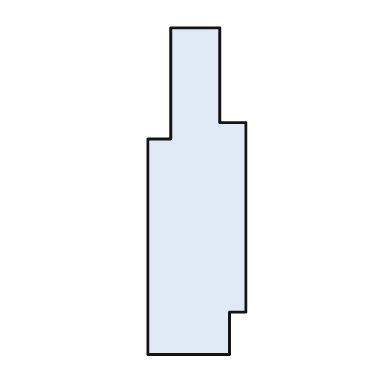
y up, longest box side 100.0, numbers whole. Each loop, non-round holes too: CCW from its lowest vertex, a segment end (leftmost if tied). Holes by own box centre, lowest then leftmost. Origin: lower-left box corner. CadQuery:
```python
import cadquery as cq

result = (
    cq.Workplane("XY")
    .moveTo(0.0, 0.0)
    .lineTo(25.0, 0.0)
    .lineTo(25.0, 13.0)
    .lineTo(30.0, 13.0)
    .lineTo(30.0, 71.0)
    .lineTo(22.0, 71.0)
    .lineTo(22.0, 100.0)
    .lineTo(7.0, 100.0)
    .lineTo(7.0, 66.0)
    .lineTo(0.0, 66.0)
    .close()
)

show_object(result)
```